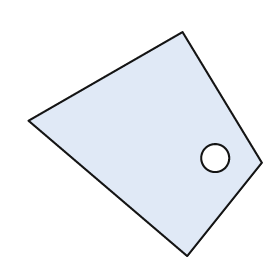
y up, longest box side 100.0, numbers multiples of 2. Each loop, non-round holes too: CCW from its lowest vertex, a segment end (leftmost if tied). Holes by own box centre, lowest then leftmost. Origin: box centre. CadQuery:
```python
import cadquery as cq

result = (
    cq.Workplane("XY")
    .moveTo(18.0, -48.0)
    .lineTo(50.0, -8.0)
    .lineTo(16.0, 48.0)
    .lineTo(-50.0, 10.0)
    .close()
    .moveTo(30.0, -6.0)
    .circle(6.0)
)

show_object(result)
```